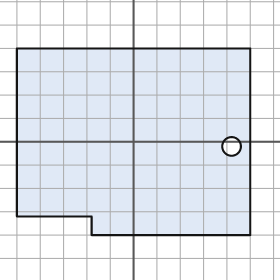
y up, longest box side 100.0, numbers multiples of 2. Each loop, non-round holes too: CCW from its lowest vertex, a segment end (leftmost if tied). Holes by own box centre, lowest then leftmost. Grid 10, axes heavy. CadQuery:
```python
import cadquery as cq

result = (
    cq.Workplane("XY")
    .moveTo(-18.0, -40.0)
    .lineTo(50.0, -40.0)
    .lineTo(50.0, 40.0)
    .lineTo(-50.0, 40.0)
    .lineTo(-50.0, -32.0)
    .lineTo(-18.0, -32.0)
    .close()
    .moveTo(42.0, -2.0)
    .circle(4.0)
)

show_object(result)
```